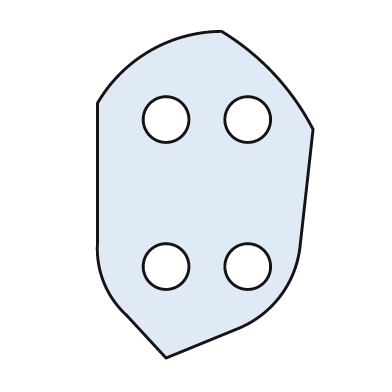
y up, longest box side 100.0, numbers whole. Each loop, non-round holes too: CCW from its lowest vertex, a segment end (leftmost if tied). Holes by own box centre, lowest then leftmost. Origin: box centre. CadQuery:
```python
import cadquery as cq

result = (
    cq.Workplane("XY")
    .moveTo(-12.0, -50.0)
    .lineTo(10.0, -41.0)
    .threePointArc((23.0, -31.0), (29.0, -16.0))
    .lineTo(33.0, 20.0)
    .threePointArc((21.0, 37.0), (5.0, 50.0))
    .threePointArc((-17.0, 44.0), (-33.0, 28.0))
    .lineTo(-33.0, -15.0)
    .threePointArc((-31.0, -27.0), (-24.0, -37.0))
    .close()
    .moveTo(-12.0, -22.0)
    .circle(7.0)
    .moveTo(13.0, -22.0)
    .circle(7.0)
    .moveTo(-12.0, 23.0)
    .circle(7.0)
    .moveTo(13.0, 23.0)
    .circle(7.0)
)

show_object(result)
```